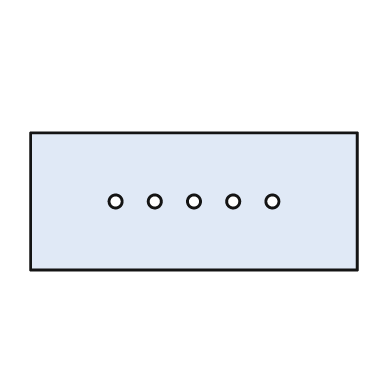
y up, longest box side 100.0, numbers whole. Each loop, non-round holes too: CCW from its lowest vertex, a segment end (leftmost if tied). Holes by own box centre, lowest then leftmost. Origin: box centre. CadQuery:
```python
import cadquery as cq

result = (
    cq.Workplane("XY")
    .moveTo(-50.0, -21.0)
    .lineTo(50.0, -21.0)
    .lineTo(50.0, 21.0)
    .lineTo(-50.0, 21.0)
    .close()
    .moveTo(-24.0, 0.0)
    .circle(2.0)
    .moveTo(-12.0, 0.0)
    .circle(2.0)
    .moveTo(0.0, 0.0)
    .circle(2.0)
    .moveTo(12.0, 0.0)
    .circle(2.0)
    .moveTo(24.0, 0.0)
    .circle(2.0)
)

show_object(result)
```